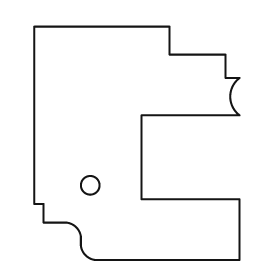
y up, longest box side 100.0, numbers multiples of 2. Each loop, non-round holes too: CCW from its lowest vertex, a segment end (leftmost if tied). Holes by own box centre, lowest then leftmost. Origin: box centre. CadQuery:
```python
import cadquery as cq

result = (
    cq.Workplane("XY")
    .moveTo(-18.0, -50.0)
    .lineTo(44.0, -50.0)
    .lineTo(44.0, -24.0)
    .lineTo(2.0, -24.0)
    .lineTo(2.0, 12.0)
    .lineTo(44.0, 12.0)
    .threePointArc((40.0, 20.0), (44.0, 28.0))
    .lineTo(38.0, 28.0)
    .lineTo(38.0, 38.0)
    .lineTo(14.0, 38.0)
    .lineTo(14.0, 50.0)
    .lineTo(-44.0, 50.0)
    .lineTo(-44.0, -26.0)
    .lineTo(-40.0, -26.0)
    .lineTo(-40.0, -34.0)
    .lineTo(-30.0, -34.0)
    .threePointArc((-26.0, -36.0), (-24.0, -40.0))
    .lineTo(-24.0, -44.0)
    .threePointArc((-22.0, -48.0), (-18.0, -50.0))
    .close()
    .moveTo(-20.0, -18.0)
    .circle(4.0)
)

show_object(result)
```